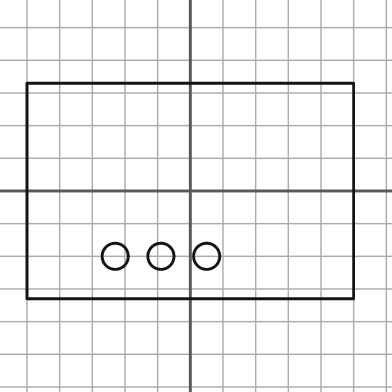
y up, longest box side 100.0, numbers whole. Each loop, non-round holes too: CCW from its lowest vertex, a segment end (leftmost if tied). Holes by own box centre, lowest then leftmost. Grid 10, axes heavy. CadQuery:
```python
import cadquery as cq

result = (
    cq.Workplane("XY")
    .moveTo(-50.0, -33.0)
    .lineTo(50.0, -33.0)
    .lineTo(50.0, 33.0)
    .lineTo(-50.0, 33.0)
    .close()
    .moveTo(-23.0, -20.0)
    .circle(4.0)
    .moveTo(-9.0, -20.0)
    .circle(4.0)
    .moveTo(5.0, -20.0)
    .circle(4.0)
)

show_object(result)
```